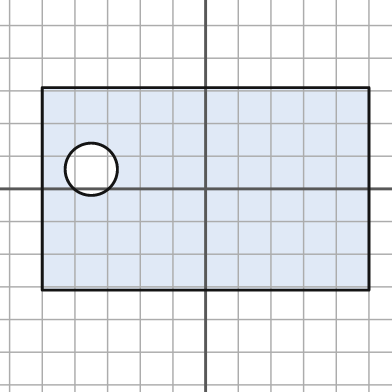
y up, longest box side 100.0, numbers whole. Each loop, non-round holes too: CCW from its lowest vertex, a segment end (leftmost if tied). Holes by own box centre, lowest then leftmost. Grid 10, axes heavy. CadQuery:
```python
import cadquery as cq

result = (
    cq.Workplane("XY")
    .moveTo(-50.0, -31.0)
    .lineTo(50.0, -31.0)
    .lineTo(50.0, 31.0)
    .lineTo(-50.0, 31.0)
    .close()
    .moveTo(-35.0, 6.0)
    .circle(8.0)
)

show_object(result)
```